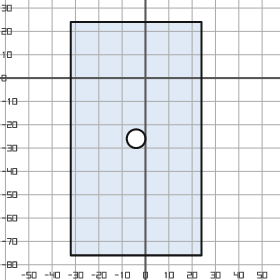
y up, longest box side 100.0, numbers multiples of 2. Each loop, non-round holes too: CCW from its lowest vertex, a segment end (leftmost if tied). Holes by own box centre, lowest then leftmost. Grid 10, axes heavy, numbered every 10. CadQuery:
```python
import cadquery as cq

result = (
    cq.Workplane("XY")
    .moveTo(-32.0, -76.0)
    .lineTo(24.0, -76.0)
    .lineTo(24.0, 24.0)
    .lineTo(-32.0, 24.0)
    .close()
    .moveTo(-4.0, -26.0)
    .circle(4.0)
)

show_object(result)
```